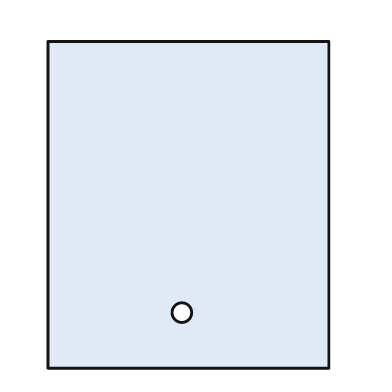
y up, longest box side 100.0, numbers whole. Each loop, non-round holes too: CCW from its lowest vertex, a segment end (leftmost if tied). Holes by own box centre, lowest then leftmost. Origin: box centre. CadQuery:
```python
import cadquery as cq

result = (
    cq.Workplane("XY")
    .moveTo(-43.0, -50.0)
    .lineTo(43.0, -50.0)
    .lineTo(43.0, 50.0)
    .lineTo(-43.0, 50.0)
    .close()
    .moveTo(-2.0, -33.0)
    .circle(3.0)
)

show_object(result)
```